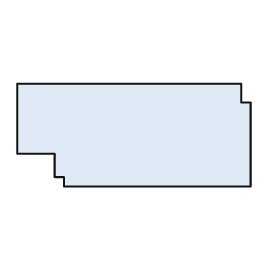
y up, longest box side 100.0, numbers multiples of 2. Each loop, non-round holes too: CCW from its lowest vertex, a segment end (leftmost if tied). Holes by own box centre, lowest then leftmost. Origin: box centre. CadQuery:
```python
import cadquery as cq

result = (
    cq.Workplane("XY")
    .moveTo(-30.0, -22.0)
    .lineTo(50.0, -22.0)
    .lineTo(50.0, 14.0)
    .lineTo(46.0, 14.0)
    .lineTo(46.0, 22.0)
    .lineTo(-50.0, 22.0)
    .lineTo(-50.0, -8.0)
    .lineTo(-34.0, -8.0)
    .lineTo(-34.0, -18.0)
    .lineTo(-30.0, -18.0)
    .close()
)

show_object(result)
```